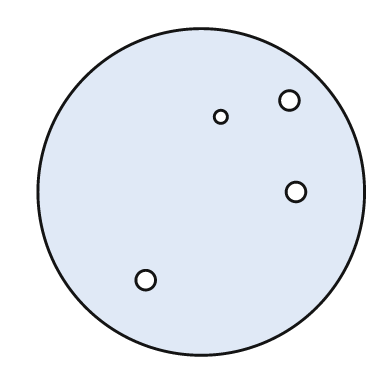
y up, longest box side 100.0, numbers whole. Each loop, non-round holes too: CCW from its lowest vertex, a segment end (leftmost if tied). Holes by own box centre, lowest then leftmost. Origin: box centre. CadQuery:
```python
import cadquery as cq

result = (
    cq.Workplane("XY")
    .moveTo(0.0, 0.0)
    .circle(50.0)
    .moveTo(-17.0, -27.0)
    .circle(3.0)
    .moveTo(29.0, 0.0)
    .circle(3.0)
    .moveTo(6.0, 23.0)
    .circle(2.0)
    .moveTo(27.0, 28.0)
    .circle(3.0)
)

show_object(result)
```